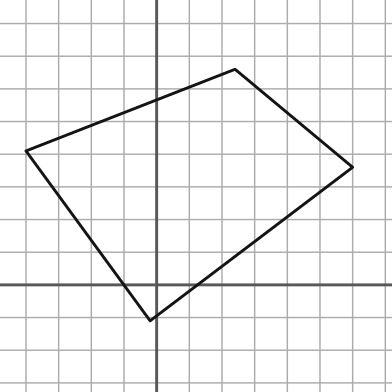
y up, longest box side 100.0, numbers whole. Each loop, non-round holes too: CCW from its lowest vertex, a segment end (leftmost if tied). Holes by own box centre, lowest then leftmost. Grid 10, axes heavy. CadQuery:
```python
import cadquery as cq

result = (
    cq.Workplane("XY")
    .moveTo(-2.0, -11.0)
    .lineTo(60.0, 36.0)
    .lineTo(24.0, 66.0)
    .lineTo(-40.0, 41.0)
    .close()
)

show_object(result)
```